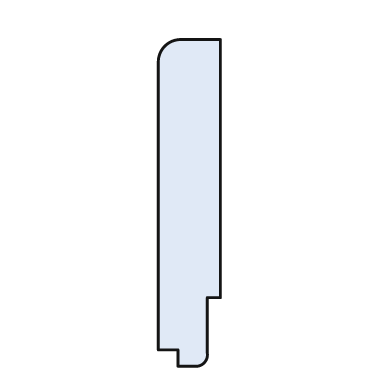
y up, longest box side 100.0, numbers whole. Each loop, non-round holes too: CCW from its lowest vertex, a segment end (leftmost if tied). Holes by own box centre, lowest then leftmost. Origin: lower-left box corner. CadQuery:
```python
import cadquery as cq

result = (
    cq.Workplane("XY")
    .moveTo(6.0, 0.0)
    .lineTo(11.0, 0.0)
    .threePointArc((14.0, 1.0), (15.0, 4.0))
    .lineTo(15.0, 21.0)
    .lineTo(19.0, 21.0)
    .lineTo(19.0, 100.0)
    .lineTo(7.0, 100.0)
    .threePointArc((2.0, 98.0), (0.0, 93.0))
    .lineTo(0.0, 5.0)
    .lineTo(6.0, 5.0)
    .close()
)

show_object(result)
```